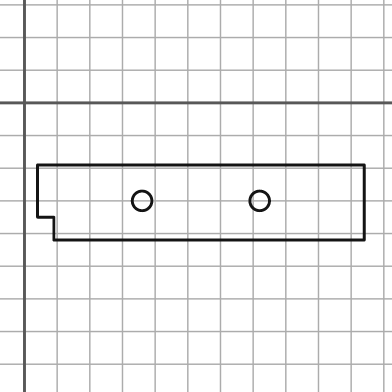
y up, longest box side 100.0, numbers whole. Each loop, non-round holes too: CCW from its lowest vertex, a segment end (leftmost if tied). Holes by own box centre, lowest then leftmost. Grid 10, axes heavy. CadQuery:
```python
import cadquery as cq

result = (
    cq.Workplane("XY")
    .moveTo(9.0, -42.0)
    .lineTo(104.0, -42.0)
    .lineTo(104.0, -19.0)
    .lineTo(4.0, -19.0)
    .lineTo(4.0, -35.0)
    .lineTo(9.0, -35.0)
    .close()
    .moveTo(36.0, -30.0)
    .circle(3.0)
    .moveTo(72.0, -30.0)
    .circle(3.0)
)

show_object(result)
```